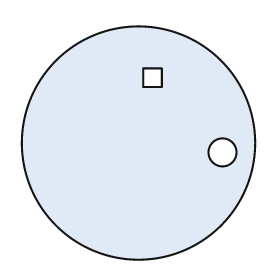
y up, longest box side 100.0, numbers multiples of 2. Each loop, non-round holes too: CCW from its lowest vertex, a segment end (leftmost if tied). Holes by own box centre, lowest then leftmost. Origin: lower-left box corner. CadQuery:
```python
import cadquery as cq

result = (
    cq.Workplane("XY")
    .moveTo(50.0, 50.0)
    .circle(50.0)
    .moveTo(86.0, 46.0)
    .circle(6.0)
    .moveTo(52.0, 74.0)
    .lineTo(60.0, 74.0)
    .lineTo(60.0, 82.0)
    .lineTo(52.0, 82.0)
    .close()
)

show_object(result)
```